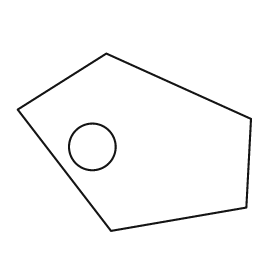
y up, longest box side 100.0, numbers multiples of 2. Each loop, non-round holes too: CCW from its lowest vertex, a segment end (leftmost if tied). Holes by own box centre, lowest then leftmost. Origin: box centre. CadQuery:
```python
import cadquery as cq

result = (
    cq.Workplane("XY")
    .moveTo(-10.0, -38.0)
    .lineTo(48.0, -28.0)
    .lineTo(50.0, 10.0)
    .lineTo(-12.0, 38.0)
    .lineTo(-50.0, 14.0)
    .close()
    .moveTo(-18.0, -2.0)
    .circle(10.0)
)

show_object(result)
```